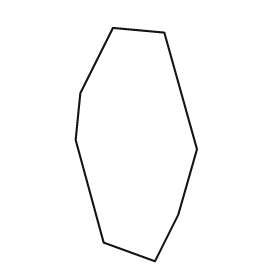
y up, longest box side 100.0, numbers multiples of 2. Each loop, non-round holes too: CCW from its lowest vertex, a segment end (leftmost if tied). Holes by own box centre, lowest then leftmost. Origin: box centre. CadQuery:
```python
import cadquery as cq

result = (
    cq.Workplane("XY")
    .moveTo(8.0, -50.0)
    .lineTo(18.0, -30.0)
    .lineTo(26.0, -2.0)
    .lineTo(12.0, 48.0)
    .lineTo(-10.0, 50.0)
    .lineTo(-24.0, 22.0)
    .lineTo(-26.0, 2.0)
    .lineTo(-14.0, -42.0)
    .close()
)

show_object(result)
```